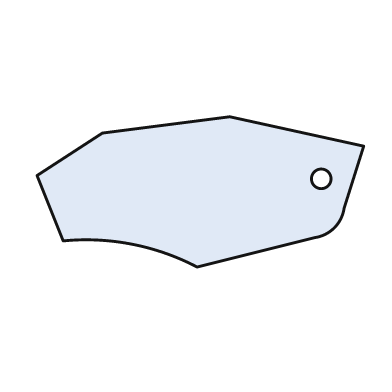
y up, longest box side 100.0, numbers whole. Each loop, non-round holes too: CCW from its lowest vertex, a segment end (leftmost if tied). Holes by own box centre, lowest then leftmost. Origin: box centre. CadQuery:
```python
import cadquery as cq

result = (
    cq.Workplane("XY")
    .moveTo(-1.0, -23.0)
    .lineTo(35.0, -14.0)
    .threePointArc((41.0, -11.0), (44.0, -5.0))
    .lineTo(50.0, 14.0)
    .lineTo(9.0, 23.0)
    .lineTo(-30.0, 18.0)
    .lineTo(-50.0, 5.0)
    .lineTo(-42.0, -15.0)
    .threePointArc((-21.0, -16.0), (-1.0, -23.0))
    .close()
    .moveTo(37.0, 4.0)
    .circle(3.0)
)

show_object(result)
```